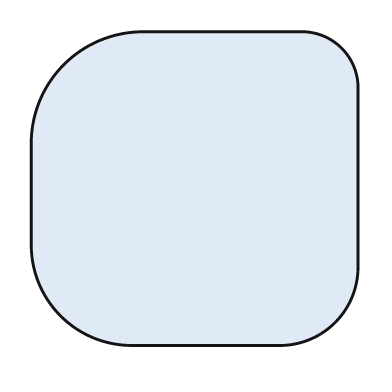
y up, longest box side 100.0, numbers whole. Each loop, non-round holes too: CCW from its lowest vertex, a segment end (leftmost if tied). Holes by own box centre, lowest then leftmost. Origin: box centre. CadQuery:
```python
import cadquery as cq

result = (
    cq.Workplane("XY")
    .moveTo(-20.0, -48.0)
    .lineTo(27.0, -48.0)
    .threePointArc((43.0, -41.0), (50.0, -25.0))
    .lineTo(50.0, 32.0)
    .threePointArc((45.0, 43.0), (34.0, 48.0))
    .lineTo(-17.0, 48.0)
    .threePointArc((-40.0, 38.0), (-50.0, 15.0))
    .lineTo(-50.0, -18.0)
    .threePointArc((-41.0, -39.0), (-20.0, -48.0))
    .close()
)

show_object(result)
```